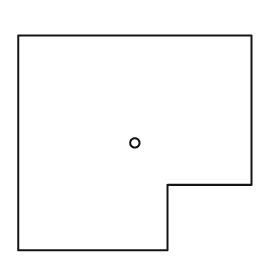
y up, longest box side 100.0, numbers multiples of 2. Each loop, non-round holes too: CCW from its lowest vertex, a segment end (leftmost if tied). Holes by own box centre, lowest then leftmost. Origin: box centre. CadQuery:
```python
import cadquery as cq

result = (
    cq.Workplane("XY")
    .moveTo(-50.0, -46.0)
    .lineTo(14.0, -46.0)
    .lineTo(14.0, -18.0)
    .lineTo(50.0, -18.0)
    .lineTo(50.0, 46.0)
    .lineTo(-50.0, 46.0)
    .close()
    .moveTo(0.0, 0.0)
    .circle(2.0)
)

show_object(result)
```